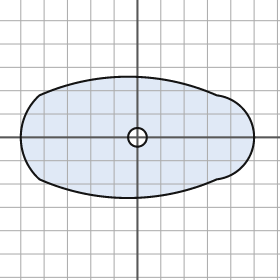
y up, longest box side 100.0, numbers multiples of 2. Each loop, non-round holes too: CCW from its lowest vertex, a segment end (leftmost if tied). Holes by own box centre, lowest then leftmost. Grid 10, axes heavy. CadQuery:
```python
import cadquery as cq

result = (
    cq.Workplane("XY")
    .moveTo(-42.0, -18.0)
    .threePointArc((-4.0, -26.0), (34.0, -18.0))
    .threePointArc((50.0, 0.0), (34.0, 18.0))
    .threePointArc((-4.0, 26.0), (-42.0, 18.0))
    .threePointArc((-50.0, 0.0), (-42.0, -18.0))
    .close()
    .moveTo(0.0, 0.0)
    .circle(4.0)
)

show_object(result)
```